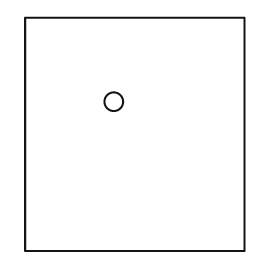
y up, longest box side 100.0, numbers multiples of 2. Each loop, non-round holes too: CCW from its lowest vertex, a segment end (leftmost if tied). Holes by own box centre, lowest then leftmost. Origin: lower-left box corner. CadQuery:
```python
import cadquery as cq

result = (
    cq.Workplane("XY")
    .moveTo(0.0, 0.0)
    .lineTo(94.0, 0.0)
    .lineTo(94.0, 100.0)
    .lineTo(0.0, 100.0)
    .close()
    .moveTo(38.0, 64.0)
    .circle(4.0)
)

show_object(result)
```